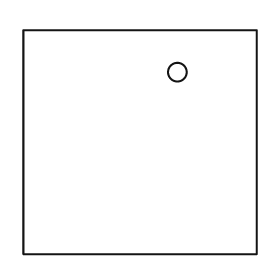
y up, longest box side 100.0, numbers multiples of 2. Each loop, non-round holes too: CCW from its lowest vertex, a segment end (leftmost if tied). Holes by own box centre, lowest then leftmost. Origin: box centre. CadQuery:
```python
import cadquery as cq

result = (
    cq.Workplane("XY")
    .moveTo(-50.0, -48.0)
    .lineTo(50.0, -48.0)
    .lineTo(50.0, 48.0)
    .lineTo(-50.0, 48.0)
    .close()
    .moveTo(16.0, 30.0)
    .circle(4.0)
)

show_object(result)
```